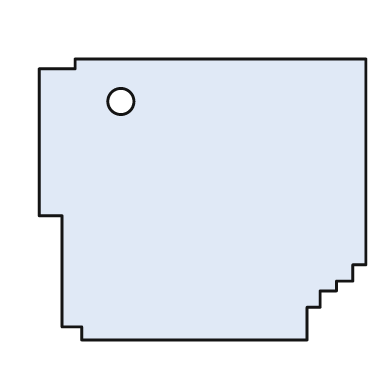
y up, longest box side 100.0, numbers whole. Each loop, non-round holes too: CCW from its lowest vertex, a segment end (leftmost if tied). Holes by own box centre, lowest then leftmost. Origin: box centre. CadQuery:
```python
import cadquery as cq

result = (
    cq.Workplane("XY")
    .moveTo(-37.0, -43.0)
    .lineTo(32.0, -43.0)
    .lineTo(32.0, -33.0)
    .lineTo(36.0, -33.0)
    .lineTo(36.0, -28.0)
    .lineTo(41.0, -28.0)
    .lineTo(41.0, -25.0)
    .lineTo(46.0, -25.0)
    .lineTo(46.0, -20.0)
    .lineTo(50.0, -20.0)
    .lineTo(50.0, 43.0)
    .lineTo(-39.0, 43.0)
    .lineTo(-39.0, 40.0)
    .lineTo(-50.0, 40.0)
    .lineTo(-50.0, -5.0)
    .lineTo(-43.0, -5.0)
    .lineTo(-43.0, -39.0)
    .lineTo(-37.0, -39.0)
    .close()
    .moveTo(-25.0, 30.0)
    .circle(4.0)
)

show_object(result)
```